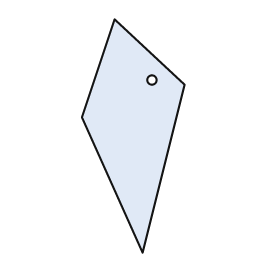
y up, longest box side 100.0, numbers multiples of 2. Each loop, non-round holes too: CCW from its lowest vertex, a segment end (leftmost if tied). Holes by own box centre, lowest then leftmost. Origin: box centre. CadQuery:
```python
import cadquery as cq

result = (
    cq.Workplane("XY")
    .moveTo(4.0, -50.0)
    .lineTo(22.0, 22.0)
    .lineTo(-8.0, 50.0)
    .lineTo(-22.0, 8.0)
    .close()
    .moveTo(8.0, 24.0)
    .circle(2.0)
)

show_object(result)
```